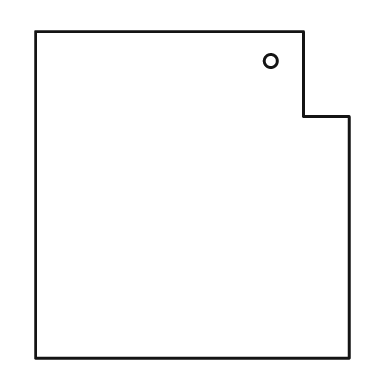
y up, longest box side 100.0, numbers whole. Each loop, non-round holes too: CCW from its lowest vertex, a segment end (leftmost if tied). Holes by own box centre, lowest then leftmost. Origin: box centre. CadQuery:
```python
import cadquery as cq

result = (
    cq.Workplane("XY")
    .moveTo(-48.0, -50.0)
    .lineTo(48.0, -50.0)
    .lineTo(48.0, 24.0)
    .lineTo(34.0, 24.0)
    .lineTo(34.0, 50.0)
    .lineTo(-48.0, 50.0)
    .close()
    .moveTo(24.0, 41.0)
    .circle(2.0)
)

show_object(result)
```